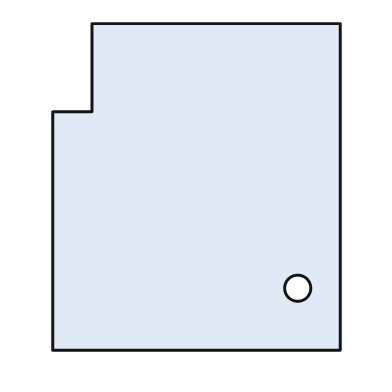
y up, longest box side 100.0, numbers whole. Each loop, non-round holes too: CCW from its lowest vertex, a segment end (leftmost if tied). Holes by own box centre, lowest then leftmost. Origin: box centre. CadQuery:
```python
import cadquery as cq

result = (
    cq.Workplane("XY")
    .moveTo(-44.0, -50.0)
    .lineTo(44.0, -50.0)
    .lineTo(44.0, 50.0)
    .lineTo(-32.0, 50.0)
    .lineTo(-32.0, 23.0)
    .lineTo(-44.0, 23.0)
    .close()
    .moveTo(31.0, -31.0)
    .circle(4.0)
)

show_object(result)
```